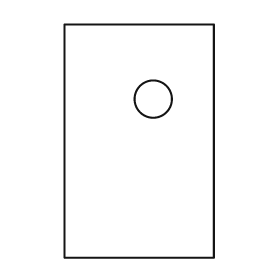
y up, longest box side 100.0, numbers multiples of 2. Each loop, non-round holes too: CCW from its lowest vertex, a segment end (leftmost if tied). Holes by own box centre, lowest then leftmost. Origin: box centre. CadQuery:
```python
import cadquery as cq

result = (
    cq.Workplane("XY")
    .moveTo(-32.0, -50.0)
    .lineTo(32.0, -50.0)
    .lineTo(32.0, 50.0)
    .lineTo(-32.0, 50.0)
    .close()
    .moveTo(6.0, 18.0)
    .circle(8.0)
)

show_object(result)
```